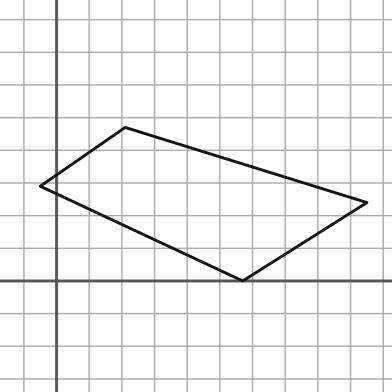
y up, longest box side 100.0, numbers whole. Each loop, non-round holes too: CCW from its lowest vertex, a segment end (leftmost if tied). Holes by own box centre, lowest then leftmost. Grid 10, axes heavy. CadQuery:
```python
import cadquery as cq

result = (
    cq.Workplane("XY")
    .moveTo(57.0, 0.0)
    .lineTo(95.0, 24.0)
    .lineTo(21.0, 47.0)
    .lineTo(-5.0, 29.0)
    .close()
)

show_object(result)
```